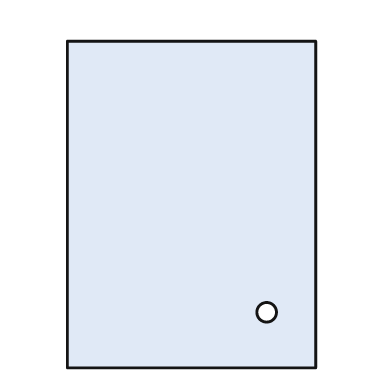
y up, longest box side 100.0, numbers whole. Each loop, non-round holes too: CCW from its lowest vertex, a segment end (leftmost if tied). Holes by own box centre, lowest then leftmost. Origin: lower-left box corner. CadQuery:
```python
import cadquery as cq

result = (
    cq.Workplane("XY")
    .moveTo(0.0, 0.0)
    .lineTo(76.0, 0.0)
    .lineTo(76.0, 100.0)
    .lineTo(0.0, 100.0)
    .close()
    .moveTo(61.0, 17.0)
    .circle(3.0)
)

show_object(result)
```